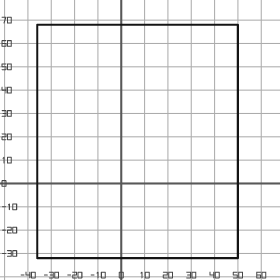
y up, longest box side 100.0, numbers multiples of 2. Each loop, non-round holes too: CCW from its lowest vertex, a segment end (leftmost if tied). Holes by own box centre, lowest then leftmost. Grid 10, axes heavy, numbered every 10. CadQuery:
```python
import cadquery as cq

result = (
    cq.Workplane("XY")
    .moveTo(-36.0, -32.0)
    .lineTo(50.0, -32.0)
    .lineTo(50.0, 68.0)
    .lineTo(-36.0, 68.0)
    .close()
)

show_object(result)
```